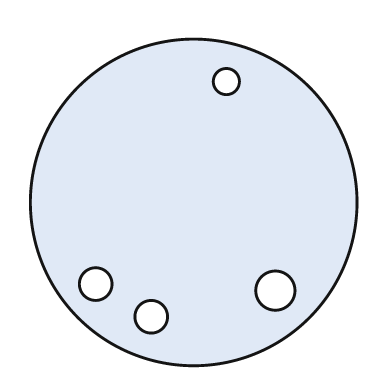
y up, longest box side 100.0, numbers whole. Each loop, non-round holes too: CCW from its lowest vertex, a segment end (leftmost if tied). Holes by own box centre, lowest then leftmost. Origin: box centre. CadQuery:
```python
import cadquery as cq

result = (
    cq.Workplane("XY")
    .moveTo(0.0, 0.0)
    .circle(50.0)
    .moveTo(-13.0, -35.0)
    .circle(5.0)
    .moveTo(25.0, -27.0)
    .circle(6.0)
    .moveTo(-30.0, -25.0)
    .circle(5.0)
    .moveTo(10.0, 37.0)
    .circle(4.0)
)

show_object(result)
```